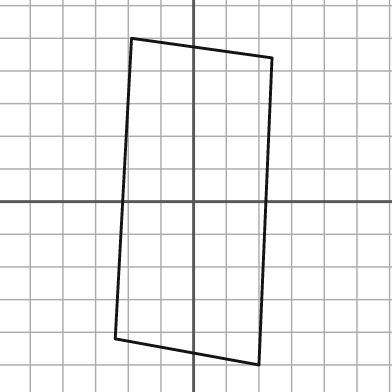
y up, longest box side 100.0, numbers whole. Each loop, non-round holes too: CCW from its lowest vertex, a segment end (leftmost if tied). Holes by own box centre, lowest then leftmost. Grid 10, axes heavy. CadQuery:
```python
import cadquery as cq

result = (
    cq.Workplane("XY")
    .moveTo(20.0, -50.0)
    .lineTo(24.0, 44.0)
    .lineTo(-19.0, 50.0)
    .lineTo(-24.0, -42.0)
    .close()
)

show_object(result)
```